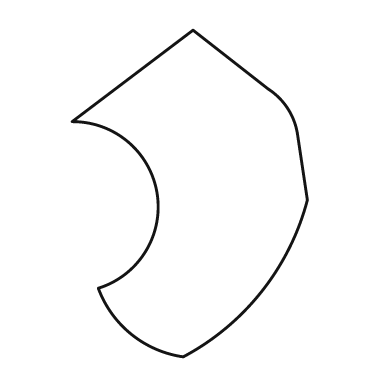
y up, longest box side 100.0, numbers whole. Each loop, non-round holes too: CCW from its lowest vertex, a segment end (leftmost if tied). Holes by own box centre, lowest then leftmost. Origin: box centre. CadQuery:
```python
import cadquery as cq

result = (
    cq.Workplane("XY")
    .moveTo(-2.0, -50.0)
    .threePointArc((22.0, -30.0), (36.0, -2.0))
    .lineTo(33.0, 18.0)
    .threePointArc((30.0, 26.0), (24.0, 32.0))
    .lineTo(1.0, 50.0)
    .lineTo(-36.0, 22.0)
    .threePointArc((-10.0, 0.0), (-28.0, -29.0))
    .threePointArc((-18.0, -43.0), (-2.0, -50.0))
    .close()
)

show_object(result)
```